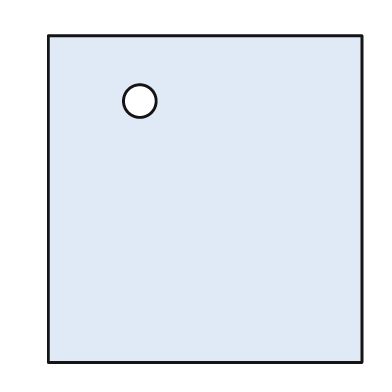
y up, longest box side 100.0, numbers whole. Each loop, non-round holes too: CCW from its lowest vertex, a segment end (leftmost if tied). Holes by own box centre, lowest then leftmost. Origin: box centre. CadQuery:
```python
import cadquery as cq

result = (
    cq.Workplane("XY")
    .moveTo(-48.0, -50.0)
    .lineTo(48.0, -50.0)
    .lineTo(48.0, 50.0)
    .lineTo(-48.0, 50.0)
    .close()
    .moveTo(-20.0, 30.0)
    .circle(5.0)
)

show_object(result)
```